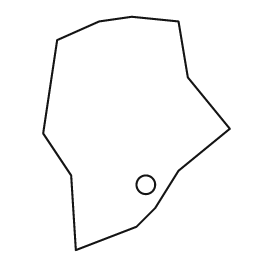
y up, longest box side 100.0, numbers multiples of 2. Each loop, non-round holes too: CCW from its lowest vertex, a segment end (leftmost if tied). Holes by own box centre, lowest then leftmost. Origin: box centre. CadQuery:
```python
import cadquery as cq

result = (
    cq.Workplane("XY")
    .moveTo(-26.0, -50.0)
    .lineTo(0.0, -40.0)
    .lineTo(8.0, -32.0)
    .lineTo(18.0, -16.0)
    .lineTo(40.0, 2.0)
    .lineTo(22.0, 24.0)
    .lineTo(18.0, 48.0)
    .lineTo(-2.0, 50.0)
    .lineTo(-16.0, 48.0)
    .lineTo(-34.0, 40.0)
    .lineTo(-40.0, 0.0)
    .lineTo(-28.0, -18.0)
    .close()
    .moveTo(4.0, -22.0)
    .circle(4.0)
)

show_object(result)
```